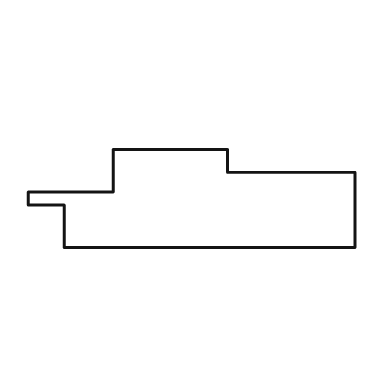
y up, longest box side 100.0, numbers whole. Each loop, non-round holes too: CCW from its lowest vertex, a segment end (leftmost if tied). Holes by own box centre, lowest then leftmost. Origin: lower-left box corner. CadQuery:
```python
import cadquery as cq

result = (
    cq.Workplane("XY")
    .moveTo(11.0, 0.0)
    .lineTo(100.0, 0.0)
    .lineTo(100.0, 23.0)
    .lineTo(61.0, 23.0)
    .lineTo(61.0, 30.0)
    .lineTo(26.0, 30.0)
    .lineTo(26.0, 17.0)
    .lineTo(0.0, 17.0)
    .lineTo(0.0, 13.0)
    .lineTo(11.0, 13.0)
    .close()
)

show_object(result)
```